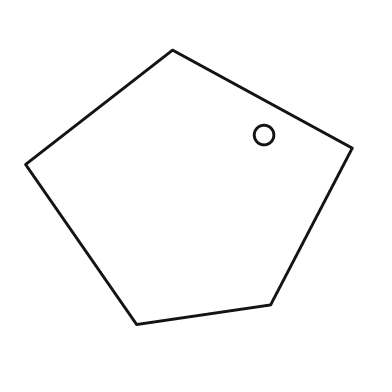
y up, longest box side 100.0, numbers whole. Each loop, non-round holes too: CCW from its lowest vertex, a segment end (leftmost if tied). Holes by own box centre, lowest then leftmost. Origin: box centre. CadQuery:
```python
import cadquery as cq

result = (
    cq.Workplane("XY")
    .moveTo(-16.0, -42.0)
    .lineTo(25.0, -36.0)
    .lineTo(50.0, 12.0)
    .lineTo(-5.0, 42.0)
    .lineTo(-50.0, 7.0)
    .close()
    .moveTo(23.0, 16.0)
    .circle(3.0)
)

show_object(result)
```